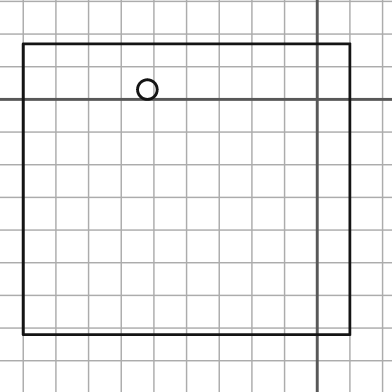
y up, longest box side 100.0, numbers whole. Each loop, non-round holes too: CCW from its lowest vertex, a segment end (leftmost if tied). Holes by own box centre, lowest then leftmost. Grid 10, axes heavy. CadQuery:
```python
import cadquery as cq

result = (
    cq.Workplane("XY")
    .moveTo(-90.0, -72.0)
    .lineTo(10.0, -72.0)
    .lineTo(10.0, 17.0)
    .lineTo(-90.0, 17.0)
    .close()
    .moveTo(-52.0, 3.0)
    .circle(3.0)
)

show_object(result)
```